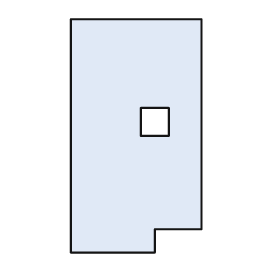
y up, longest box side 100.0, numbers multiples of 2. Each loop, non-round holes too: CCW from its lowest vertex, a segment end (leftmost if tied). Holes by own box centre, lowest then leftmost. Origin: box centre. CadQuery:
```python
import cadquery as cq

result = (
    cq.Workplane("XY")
    .moveTo(-28.0, -50.0)
    .lineTo(8.0, -50.0)
    .lineTo(8.0, -40.0)
    .lineTo(28.0, -40.0)
    .lineTo(28.0, 50.0)
    .lineTo(-28.0, 50.0)
    .close()
    .moveTo(2.0, 0.0)
    .lineTo(14.0, 0.0)
    .lineTo(14.0, 12.0)
    .lineTo(2.0, 12.0)
    .close()
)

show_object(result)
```